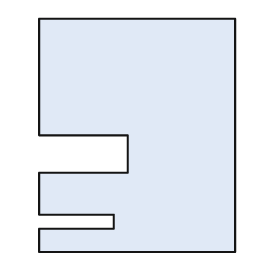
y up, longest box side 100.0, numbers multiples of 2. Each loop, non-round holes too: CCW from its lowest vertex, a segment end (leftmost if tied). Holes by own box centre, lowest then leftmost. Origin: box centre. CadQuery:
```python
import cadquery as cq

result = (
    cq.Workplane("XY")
    .moveTo(-42.0, -50.0)
    .lineTo(42.0, -50.0)
    .lineTo(42.0, 50.0)
    .lineTo(-42.0, 50.0)
    .lineTo(-42.0, 0.0)
    .lineTo(-4.0, 0.0)
    .lineTo(-4.0, -16.0)
    .lineTo(-42.0, -16.0)
    .lineTo(-42.0, -34.0)
    .lineTo(-10.0, -34.0)
    .lineTo(-10.0, -40.0)
    .lineTo(-42.0, -40.0)
    .close()
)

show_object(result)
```